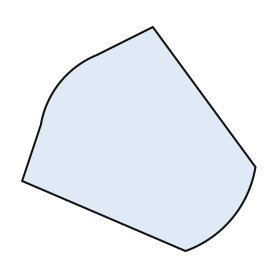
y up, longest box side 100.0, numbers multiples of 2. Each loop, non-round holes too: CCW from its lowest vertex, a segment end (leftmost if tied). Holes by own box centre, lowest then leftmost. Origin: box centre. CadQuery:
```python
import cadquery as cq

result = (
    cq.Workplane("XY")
    .moveTo(20.0, -48.0)
    .threePointArc((40.0, -34.0), (50.0, -12.0))
    .lineTo(6.0, 48.0)
    .lineTo(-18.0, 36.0)
    .threePointArc((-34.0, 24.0), (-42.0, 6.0))
    .lineTo(-50.0, -18.0)
    .close()
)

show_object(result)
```